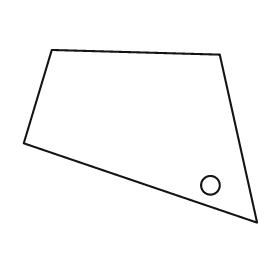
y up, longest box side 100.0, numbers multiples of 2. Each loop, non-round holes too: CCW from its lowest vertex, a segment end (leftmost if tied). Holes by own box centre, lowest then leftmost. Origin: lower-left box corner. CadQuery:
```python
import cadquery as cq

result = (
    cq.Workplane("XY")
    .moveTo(100.0, 0.0)
    .lineTo(84.0, 72.0)
    .lineTo(12.0, 74.0)
    .lineTo(0.0, 34.0)
    .close()
    .moveTo(80.0, 16.0)
    .circle(4.0)
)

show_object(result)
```